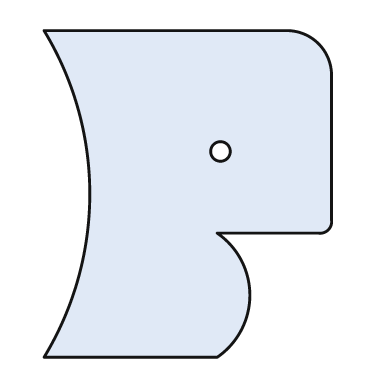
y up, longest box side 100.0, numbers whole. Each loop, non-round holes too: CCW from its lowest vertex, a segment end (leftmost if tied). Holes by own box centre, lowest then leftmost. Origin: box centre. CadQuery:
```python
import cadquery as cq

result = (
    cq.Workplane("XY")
    .moveTo(-44.0, -50.0)
    .lineTo(9.0, -50.0)
    .threePointArc((19.0, -31.0), (9.0, -12.0))
    .lineTo(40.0, -12.0)
    .threePointArc((43.0, -11.0), (44.0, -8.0))
    .lineTo(44.0, 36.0)
    .threePointArc((40.0, 46.0), (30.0, 50.0))
    .lineTo(-44.0, 50.0)
    .threePointArc((-30.0, 0.0), (-44.0, -50.0))
    .close()
    .moveTo(10.0, 13.0)
    .circle(3.0)
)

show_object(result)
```